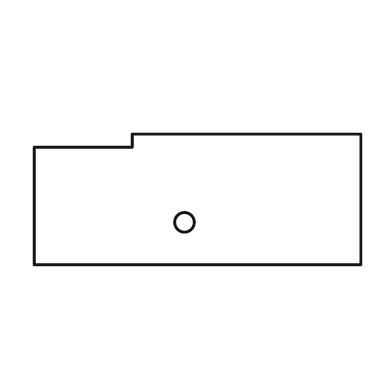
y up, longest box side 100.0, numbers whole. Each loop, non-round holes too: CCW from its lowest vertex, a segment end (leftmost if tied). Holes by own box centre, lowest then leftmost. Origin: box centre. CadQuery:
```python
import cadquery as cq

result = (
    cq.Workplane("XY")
    .moveTo(-50.0, -20.0)
    .lineTo(50.0, -20.0)
    .lineTo(50.0, 20.0)
    .lineTo(-20.0, 20.0)
    .lineTo(-20.0, 16.0)
    .lineTo(-50.0, 16.0)
    .close()
    .moveTo(-4.0, -7.0)
    .circle(3.0)
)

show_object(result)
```